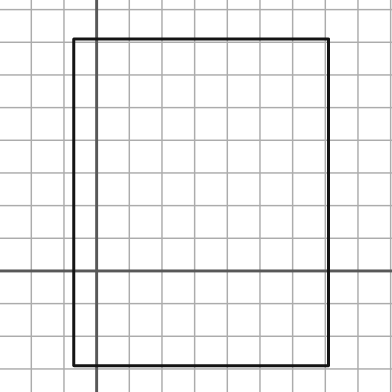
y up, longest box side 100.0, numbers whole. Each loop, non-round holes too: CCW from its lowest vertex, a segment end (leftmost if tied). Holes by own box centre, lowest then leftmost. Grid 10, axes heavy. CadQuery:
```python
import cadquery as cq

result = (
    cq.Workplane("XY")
    .moveTo(-7.0, -29.0)
    .lineTo(71.0, -29.0)
    .lineTo(71.0, 71.0)
    .lineTo(-7.0, 71.0)
    .close()
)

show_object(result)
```